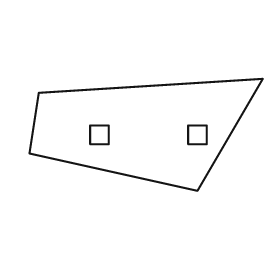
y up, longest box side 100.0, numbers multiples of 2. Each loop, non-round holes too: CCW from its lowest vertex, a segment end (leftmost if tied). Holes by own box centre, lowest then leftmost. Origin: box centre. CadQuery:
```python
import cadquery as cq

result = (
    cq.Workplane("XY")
    .moveTo(22.0, -24.0)
    .lineTo(50.0, 24.0)
    .lineTo(-46.0, 18.0)
    .lineTo(-50.0, -8.0)
    .close()
    .moveTo(-24.0, -4.0)
    .lineTo(-16.0, -4.0)
    .lineTo(-16.0, 4.0)
    .lineTo(-24.0, 4.0)
    .close()
    .moveTo(18.0, -4.0)
    .lineTo(26.0, -4.0)
    .lineTo(26.0, 4.0)
    .lineTo(18.0, 4.0)
    .close()
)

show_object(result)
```